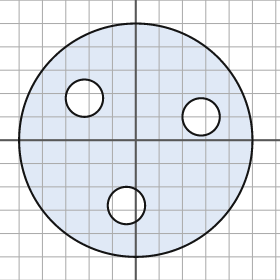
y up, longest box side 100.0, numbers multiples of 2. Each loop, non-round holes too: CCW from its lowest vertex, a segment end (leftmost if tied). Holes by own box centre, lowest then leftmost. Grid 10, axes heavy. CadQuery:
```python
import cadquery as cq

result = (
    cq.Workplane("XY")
    .moveTo(0.0, 0.0)
    .circle(50.0)
    .moveTo(-4.0, -28.0)
    .circle(8.0)
    .moveTo(28.0, 10.0)
    .circle(8.0)
    .moveTo(-22.0, 18.0)
    .circle(8.0)
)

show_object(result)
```